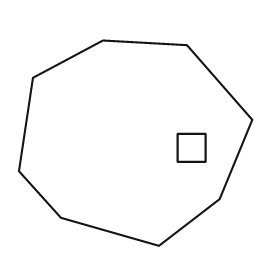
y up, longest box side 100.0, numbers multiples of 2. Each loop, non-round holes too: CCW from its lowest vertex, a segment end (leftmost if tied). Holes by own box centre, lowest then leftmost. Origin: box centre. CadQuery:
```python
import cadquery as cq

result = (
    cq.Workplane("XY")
    .moveTo(10.0, -44.0)
    .lineTo(36.0, -24.0)
    .lineTo(50.0, 10.0)
    .lineTo(22.0, 42.0)
    .lineTo(-14.0, 44.0)
    .lineTo(-44.0, 28.0)
    .lineTo(-50.0, -12.0)
    .lineTo(-32.0, -32.0)
    .close()
    .moveTo(18.0, -8.0)
    .lineTo(30.0, -8.0)
    .lineTo(30.0, 4.0)
    .lineTo(18.0, 4.0)
    .close()
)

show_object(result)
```